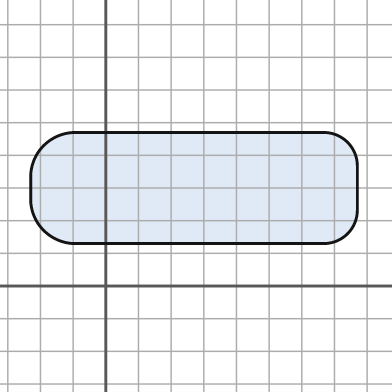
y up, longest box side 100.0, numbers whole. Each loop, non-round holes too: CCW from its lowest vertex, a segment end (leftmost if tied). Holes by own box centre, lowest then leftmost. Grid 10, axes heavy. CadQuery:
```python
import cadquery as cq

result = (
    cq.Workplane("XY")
    .moveTo(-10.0, 13.0)
    .lineTo(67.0, 13.0)
    .threePointArc((74.0, 16.0), (77.0, 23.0))
    .lineTo(77.0, 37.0)
    .threePointArc((74.0, 44.0), (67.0, 47.0))
    .lineTo(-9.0, 47.0)
    .threePointArc((-19.0, 43.0), (-23.0, 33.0))
    .lineTo(-23.0, 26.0)
    .threePointArc((-19.0, 17.0), (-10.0, 13.0))
    .close()
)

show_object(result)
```